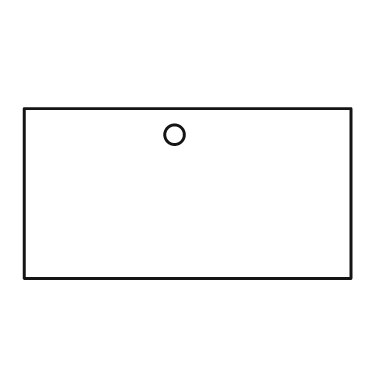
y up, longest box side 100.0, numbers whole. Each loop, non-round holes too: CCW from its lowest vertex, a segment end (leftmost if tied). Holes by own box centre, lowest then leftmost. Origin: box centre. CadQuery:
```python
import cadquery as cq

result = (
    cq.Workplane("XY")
    .moveTo(-50.0, -26.0)
    .lineTo(50.0, -26.0)
    .lineTo(50.0, 26.0)
    .lineTo(-50.0, 26.0)
    .close()
    .moveTo(-4.0, 18.0)
    .circle(3.0)
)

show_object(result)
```